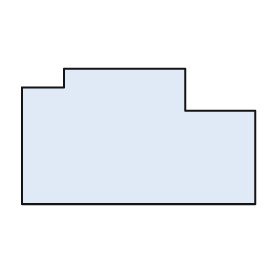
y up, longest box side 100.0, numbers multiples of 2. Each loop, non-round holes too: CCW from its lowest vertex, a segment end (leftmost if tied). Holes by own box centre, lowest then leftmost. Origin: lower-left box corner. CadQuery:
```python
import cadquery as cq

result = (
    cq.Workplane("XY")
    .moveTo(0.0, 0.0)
    .lineTo(100.0, 0.0)
    .lineTo(100.0, 40.0)
    .lineTo(70.0, 40.0)
    .lineTo(70.0, 58.0)
    .lineTo(18.0, 58.0)
    .lineTo(18.0, 50.0)
    .lineTo(0.0, 50.0)
    .close()
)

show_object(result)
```